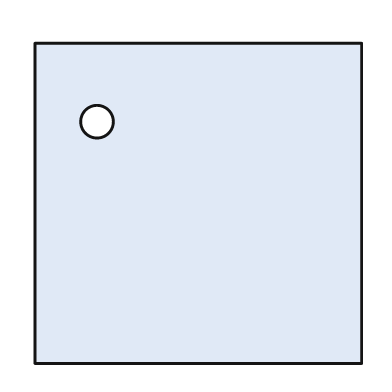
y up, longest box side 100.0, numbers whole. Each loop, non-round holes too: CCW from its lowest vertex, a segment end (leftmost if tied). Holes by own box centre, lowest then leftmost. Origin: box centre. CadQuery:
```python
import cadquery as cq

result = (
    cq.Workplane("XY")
    .moveTo(-50.0, -49.0)
    .lineTo(50.0, -49.0)
    .lineTo(50.0, 49.0)
    .lineTo(-50.0, 49.0)
    .close()
    .moveTo(-31.0, 25.0)
    .circle(5.0)
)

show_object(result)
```